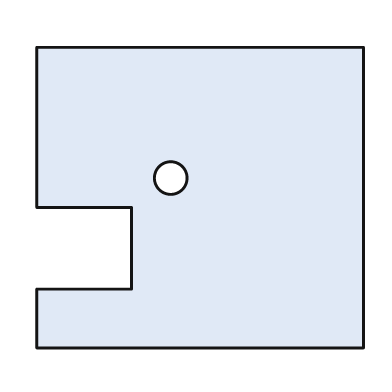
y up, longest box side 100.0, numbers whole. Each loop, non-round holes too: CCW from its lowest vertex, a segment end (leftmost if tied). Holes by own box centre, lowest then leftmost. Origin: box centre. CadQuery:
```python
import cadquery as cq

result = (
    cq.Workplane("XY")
    .moveTo(-50.0, -46.0)
    .lineTo(50.0, -46.0)
    .lineTo(50.0, 46.0)
    .lineTo(-50.0, 46.0)
    .lineTo(-50.0, -3.0)
    .lineTo(-21.0, -3.0)
    .lineTo(-21.0, -28.0)
    .lineTo(-50.0, -28.0)
    .close()
    .moveTo(-9.0, 6.0)
    .circle(5.0)
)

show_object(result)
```